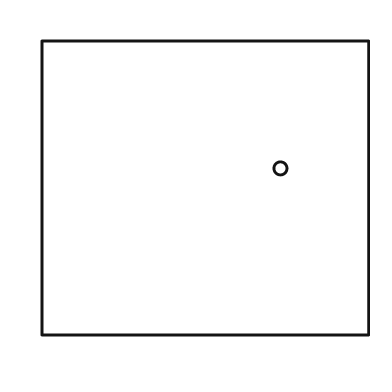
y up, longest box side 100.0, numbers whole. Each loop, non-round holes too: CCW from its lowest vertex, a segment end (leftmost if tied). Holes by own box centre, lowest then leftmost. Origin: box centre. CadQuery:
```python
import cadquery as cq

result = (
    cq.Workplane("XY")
    .moveTo(-50.0, -45.0)
    .lineTo(50.0, -45.0)
    .lineTo(50.0, 45.0)
    .lineTo(-50.0, 45.0)
    .close()
    .moveTo(23.0, 6.0)
    .circle(2.0)
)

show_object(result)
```